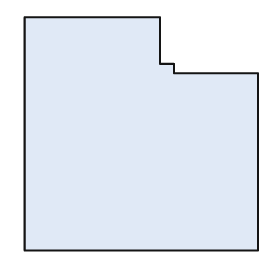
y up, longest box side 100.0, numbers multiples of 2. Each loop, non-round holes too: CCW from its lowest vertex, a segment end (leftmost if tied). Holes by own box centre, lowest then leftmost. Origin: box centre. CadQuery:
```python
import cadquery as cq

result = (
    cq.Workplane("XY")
    .moveTo(-50.0, -50.0)
    .lineTo(50.0, -50.0)
    .lineTo(50.0, 26.0)
    .lineTo(14.0, 26.0)
    .lineTo(14.0, 30.0)
    .lineTo(8.0, 30.0)
    .lineTo(8.0, 50.0)
    .lineTo(-50.0, 50.0)
    .close()
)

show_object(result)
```